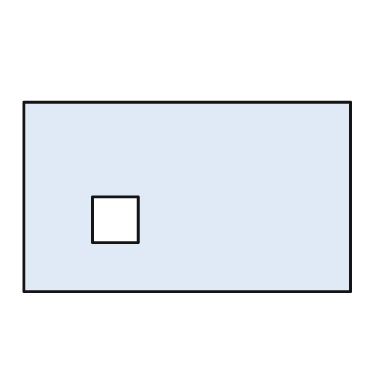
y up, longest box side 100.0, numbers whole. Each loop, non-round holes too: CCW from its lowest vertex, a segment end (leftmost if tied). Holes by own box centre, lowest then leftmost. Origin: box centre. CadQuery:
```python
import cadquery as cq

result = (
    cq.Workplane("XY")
    .moveTo(-50.0, -29.0)
    .lineTo(50.0, -29.0)
    .lineTo(50.0, 29.0)
    .lineTo(-50.0, 29.0)
    .close()
    .moveTo(-29.0, -14.0)
    .lineTo(-15.0, -14.0)
    .lineTo(-15.0, 0.0)
    .lineTo(-29.0, 0.0)
    .close()
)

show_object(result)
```